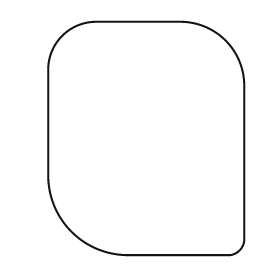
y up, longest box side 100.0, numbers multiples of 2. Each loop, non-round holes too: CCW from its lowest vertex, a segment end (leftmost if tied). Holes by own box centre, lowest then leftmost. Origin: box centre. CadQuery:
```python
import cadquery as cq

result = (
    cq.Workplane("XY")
    .moveTo(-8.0, -50.0)
    .lineTo(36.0, -50.0)
    .threePointArc((40.0, -48.0), (42.0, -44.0))
    .lineTo(42.0, 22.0)
    .threePointArc((34.0, 42.0), (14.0, 50.0))
    .lineTo(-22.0, 50.0)
    .threePointArc((-36.0, 44.0), (-42.0, 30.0))
    .lineTo(-42.0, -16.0)
    .threePointArc((-32.0, -40.0), (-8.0, -50.0))
    .close()
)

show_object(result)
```